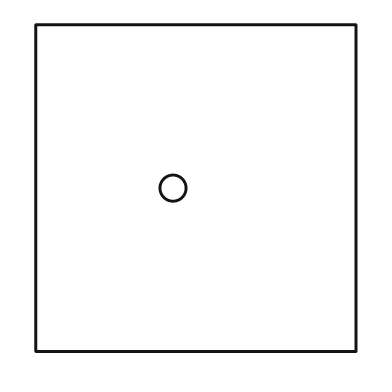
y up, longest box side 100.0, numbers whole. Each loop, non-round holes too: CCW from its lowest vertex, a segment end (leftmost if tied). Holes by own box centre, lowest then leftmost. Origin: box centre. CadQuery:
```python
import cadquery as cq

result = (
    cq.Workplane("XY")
    .moveTo(-49.0, -50.0)
    .lineTo(49.0, -50.0)
    .lineTo(49.0, 50.0)
    .lineTo(-49.0, 50.0)
    .close()
    .moveTo(-7.0, 0.0)
    .circle(4.0)
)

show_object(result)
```